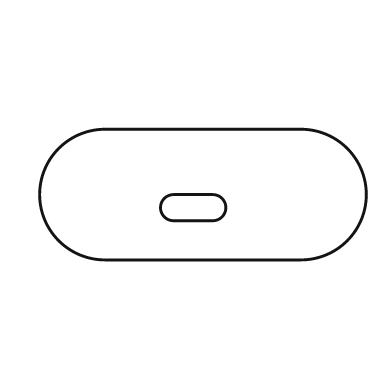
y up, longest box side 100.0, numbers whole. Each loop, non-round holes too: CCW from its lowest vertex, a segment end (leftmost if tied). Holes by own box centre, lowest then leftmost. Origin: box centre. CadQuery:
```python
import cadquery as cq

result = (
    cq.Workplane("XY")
    .moveTo(-30.0, -20.0)
    .lineTo(30.0, -20.0)
    .threePointArc((50.0, 0.0), (30.0, 20.0))
    .lineTo(-30.0, 20.0)
    .threePointArc((-50.0, 0.0), (-30.0, -20.0))
    .close()
    .moveTo(-9.0, -8.0)
    .lineTo(3.0, -8.0)
    .threePointArc((7.0, -4.0), (3.0, 0.0))
    .lineTo(-9.0, 0.0)
    .threePointArc((-13.0, -4.0), (-9.0, -8.0))
    .close()
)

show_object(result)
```